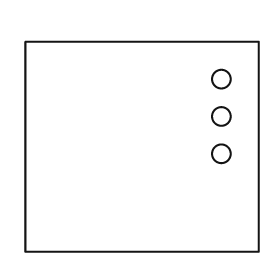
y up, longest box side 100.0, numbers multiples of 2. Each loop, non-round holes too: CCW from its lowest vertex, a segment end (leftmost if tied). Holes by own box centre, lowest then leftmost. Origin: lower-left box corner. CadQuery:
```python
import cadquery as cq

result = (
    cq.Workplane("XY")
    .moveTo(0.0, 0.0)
    .lineTo(100.0, 0.0)
    .lineTo(100.0, 90.0)
    .lineTo(0.0, 90.0)
    .close()
    .moveTo(84.0, 42.0)
    .circle(4.0)
    .moveTo(84.0, 58.0)
    .circle(4.0)
    .moveTo(84.0, 74.0)
    .circle(4.0)
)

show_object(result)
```